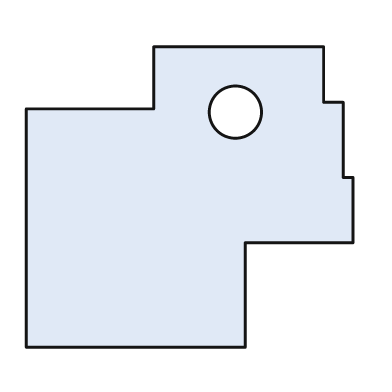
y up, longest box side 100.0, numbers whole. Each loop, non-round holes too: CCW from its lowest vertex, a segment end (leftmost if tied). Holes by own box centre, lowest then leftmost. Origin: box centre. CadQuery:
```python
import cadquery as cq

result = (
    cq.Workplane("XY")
    .moveTo(-50.0, -46.0)
    .lineTo(17.0, -46.0)
    .lineTo(17.0, -14.0)
    .lineTo(50.0, -14.0)
    .lineTo(50.0, 6.0)
    .lineTo(47.0, 6.0)
    .lineTo(47.0, 29.0)
    .lineTo(41.0, 29.0)
    .lineTo(41.0, 46.0)
    .lineTo(-11.0, 46.0)
    .lineTo(-11.0, 27.0)
    .lineTo(-50.0, 27.0)
    .close()
    .moveTo(14.0, 26.0)
    .circle(8.0)
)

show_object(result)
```